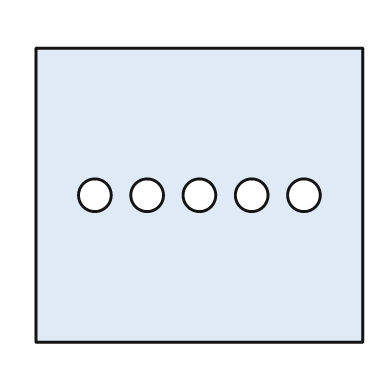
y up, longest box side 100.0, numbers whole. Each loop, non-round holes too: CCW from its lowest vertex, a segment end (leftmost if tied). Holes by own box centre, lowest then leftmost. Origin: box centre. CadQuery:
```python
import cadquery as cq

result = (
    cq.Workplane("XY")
    .moveTo(-50.0, -45.0)
    .lineTo(50.0, -45.0)
    .lineTo(50.0, 45.0)
    .lineTo(-50.0, 45.0)
    .close()
    .moveTo(-32.0, 0.0)
    .circle(5.0)
    .moveTo(-16.0, 0.0)
    .circle(5.0)
    .moveTo(0.0, 0.0)
    .circle(5.0)
    .moveTo(16.0, 0.0)
    .circle(5.0)
    .moveTo(32.0, 0.0)
    .circle(5.0)
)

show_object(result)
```